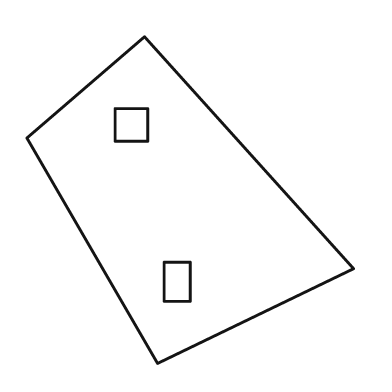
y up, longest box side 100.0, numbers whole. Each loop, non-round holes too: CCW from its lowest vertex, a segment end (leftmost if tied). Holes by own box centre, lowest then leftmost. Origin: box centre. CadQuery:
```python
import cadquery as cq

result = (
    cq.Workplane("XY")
    .moveTo(-10.0, -50.0)
    .lineTo(50.0, -21.0)
    .lineTo(-14.0, 50.0)
    .lineTo(-50.0, 19.0)
    .close()
    .moveTo(-8.0, -31.0)
    .lineTo(0.0, -31.0)
    .lineTo(0.0, -19.0)
    .lineTo(-8.0, -19.0)
    .close()
    .moveTo(-23.0, 18.0)
    .lineTo(-13.0, 18.0)
    .lineTo(-13.0, 28.0)
    .lineTo(-23.0, 28.0)
    .close()
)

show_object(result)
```